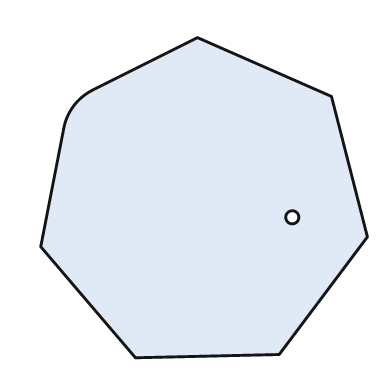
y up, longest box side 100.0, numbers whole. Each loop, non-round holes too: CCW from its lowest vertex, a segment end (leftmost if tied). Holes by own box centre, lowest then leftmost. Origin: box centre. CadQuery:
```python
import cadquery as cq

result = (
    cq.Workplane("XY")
    .moveTo(-21.0, -49.0)
    .lineTo(23.0, -48.0)
    .lineTo(50.0, -12.0)
    .lineTo(39.0, 31.0)
    .lineTo(-2.0, 49.0)
    .lineTo(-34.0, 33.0)
    .threePointArc((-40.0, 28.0), (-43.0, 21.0))
    .lineTo(-50.0, -15.0)
    .close()
    .moveTo(27.0, -6.0)
    .circle(2.0)
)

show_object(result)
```